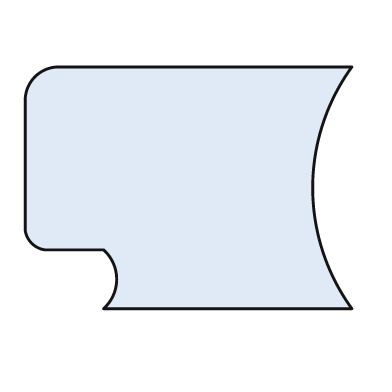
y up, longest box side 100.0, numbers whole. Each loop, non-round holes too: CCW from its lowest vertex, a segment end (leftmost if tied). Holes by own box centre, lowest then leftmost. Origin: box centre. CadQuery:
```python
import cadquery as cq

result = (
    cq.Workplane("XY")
    .moveTo(-26.0, -37.0)
    .lineTo(50.0, -37.0)
    .threePointArc((38.0, 0.0), (50.0, 37.0))
    .lineTo(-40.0, 37.0)
    .threePointArc((-47.0, 34.0), (-50.0, 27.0))
    .lineTo(-50.0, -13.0)
    .threePointArc((-48.0, -17.0), (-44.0, -19.0))
    .lineTo(-26.0, -19.0)
    .threePointArc((-22.0, -28.0), (-26.0, -37.0))
    .close()
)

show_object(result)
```